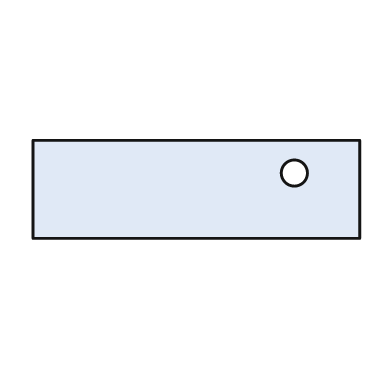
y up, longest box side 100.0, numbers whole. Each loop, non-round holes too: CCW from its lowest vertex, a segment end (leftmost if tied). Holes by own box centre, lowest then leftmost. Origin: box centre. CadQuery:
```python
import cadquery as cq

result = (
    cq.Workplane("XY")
    .moveTo(-50.0, -15.0)
    .lineTo(50.0, -15.0)
    .lineTo(50.0, 15.0)
    .lineTo(-50.0, 15.0)
    .close()
    .moveTo(30.0, 5.0)
    .circle(4.0)
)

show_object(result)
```